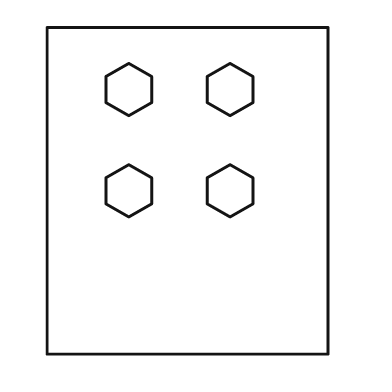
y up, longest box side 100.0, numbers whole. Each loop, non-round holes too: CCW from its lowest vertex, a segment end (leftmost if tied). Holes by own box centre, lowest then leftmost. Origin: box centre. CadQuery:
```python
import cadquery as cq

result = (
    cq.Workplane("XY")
    .moveTo(-43.0, -50.0)
    .lineTo(43.0, -50.0)
    .lineTo(43.0, 50.0)
    .lineTo(-43.0, 50.0)
    .close()
    .moveTo(-18.0, -8.0)
    .lineTo(-11.0, -4.0)
    .lineTo(-11.0, 4.0)
    .lineTo(-18.0, 8.0)
    .lineTo(-25.0, 4.0)
    .lineTo(-25.0, -4.0)
    .close()
    .moveTo(13.0, -8.0)
    .lineTo(20.0, -4.0)
    .lineTo(20.0, 4.0)
    .lineTo(13.0, 8.0)
    .lineTo(6.0, 4.0)
    .lineTo(6.0, -4.0)
    .close()
    .moveTo(-18.0, 23.0)
    .lineTo(-11.0, 27.0)
    .lineTo(-11.0, 35.0)
    .lineTo(-18.0, 39.0)
    .lineTo(-25.0, 35.0)
    .lineTo(-25.0, 27.0)
    .close()
    .moveTo(13.0, 23.0)
    .lineTo(20.0, 27.0)
    .lineTo(20.0, 35.0)
    .lineTo(13.0, 39.0)
    .lineTo(6.0, 35.0)
    .lineTo(6.0, 27.0)
    .close()
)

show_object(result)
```